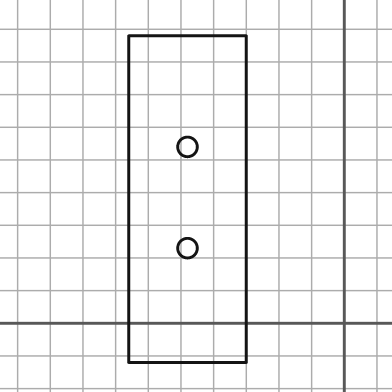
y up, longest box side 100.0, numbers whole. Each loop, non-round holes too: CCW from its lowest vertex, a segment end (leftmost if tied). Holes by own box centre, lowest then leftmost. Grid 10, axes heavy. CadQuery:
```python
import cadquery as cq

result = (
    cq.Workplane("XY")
    .moveTo(-66.0, -12.0)
    .lineTo(-30.0, -12.0)
    .lineTo(-30.0, 88.0)
    .lineTo(-66.0, 88.0)
    .close()
    .moveTo(-48.0, 23.0)
    .circle(3.0)
    .moveTo(-48.0, 54.0)
    .circle(3.0)
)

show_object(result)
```